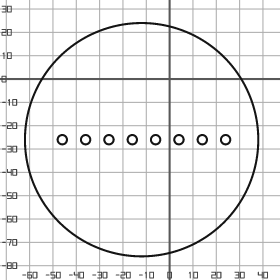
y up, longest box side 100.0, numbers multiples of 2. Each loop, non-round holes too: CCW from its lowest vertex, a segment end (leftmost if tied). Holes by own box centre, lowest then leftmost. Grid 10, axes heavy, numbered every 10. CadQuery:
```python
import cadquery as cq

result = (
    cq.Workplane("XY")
    .moveTo(-12.0, -26.0)
    .circle(50.0)
    .moveTo(-46.0, -26.0)
    .circle(2.0)
    .moveTo(-36.0, -26.0)
    .circle(2.0)
    .moveTo(-26.0, -26.0)
    .circle(2.0)
    .moveTo(-16.0, -26.0)
    .circle(2.0)
    .moveTo(-6.0, -26.0)
    .circle(2.0)
    .moveTo(4.0, -26.0)
    .circle(2.0)
    .moveTo(14.0, -26.0)
    .circle(2.0)
    .moveTo(24.0, -26.0)
    .circle(2.0)
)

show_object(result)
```